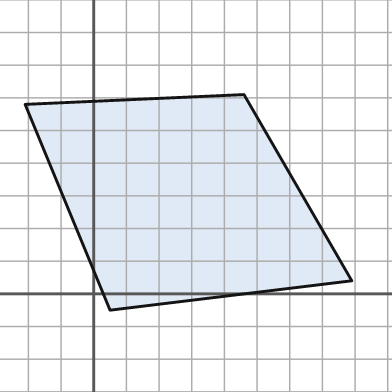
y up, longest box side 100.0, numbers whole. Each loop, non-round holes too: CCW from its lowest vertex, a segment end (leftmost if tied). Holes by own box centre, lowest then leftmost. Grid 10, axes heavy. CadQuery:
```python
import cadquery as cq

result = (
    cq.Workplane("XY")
    .moveTo(5.0, -5.0)
    .lineTo(79.0, 4.0)
    .lineTo(46.0, 61.0)
    .lineTo(-21.0, 58.0)
    .close()
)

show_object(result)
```